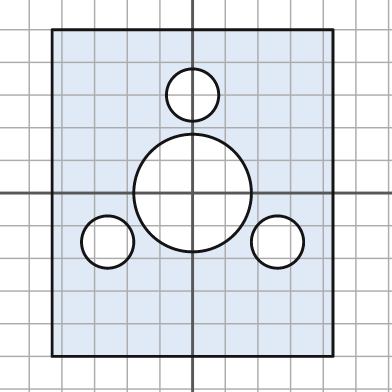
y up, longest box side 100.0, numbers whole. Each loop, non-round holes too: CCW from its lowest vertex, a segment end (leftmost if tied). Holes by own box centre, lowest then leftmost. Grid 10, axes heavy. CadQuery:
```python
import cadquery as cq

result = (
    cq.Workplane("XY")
    .moveTo(-43.0, -50.0)
    .lineTo(43.0, -50.0)
    .lineTo(43.0, 50.0)
    .lineTo(-43.0, 50.0)
    .close()
    .moveTo(-26.0, -15.0)
    .circle(8.0)
    .moveTo(26.0, -15.0)
    .circle(8.0)
    .moveTo(0.0, 0.0)
    .circle(18.0)
    .moveTo(0.0, 30.0)
    .circle(8.0)
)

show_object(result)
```